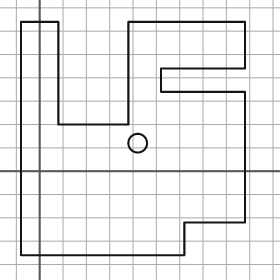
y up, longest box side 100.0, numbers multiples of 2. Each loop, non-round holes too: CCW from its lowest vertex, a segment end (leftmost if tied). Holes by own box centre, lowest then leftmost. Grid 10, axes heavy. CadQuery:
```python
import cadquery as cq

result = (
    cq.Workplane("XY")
    .moveTo(-8.0, -36.0)
    .lineTo(62.0, -36.0)
    .lineTo(62.0, -22.0)
    .lineTo(88.0, -22.0)
    .lineTo(88.0, 34.0)
    .lineTo(52.0, 34.0)
    .lineTo(52.0, 44.0)
    .lineTo(88.0, 44.0)
    .lineTo(88.0, 64.0)
    .lineTo(38.0, 64.0)
    .lineTo(38.0, 20.0)
    .lineTo(8.0, 20.0)
    .lineTo(8.0, 64.0)
    .lineTo(-8.0, 64.0)
    .close()
    .moveTo(42.0, 12.0)
    .circle(4.0)
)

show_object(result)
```